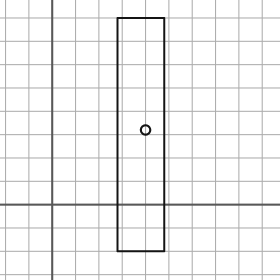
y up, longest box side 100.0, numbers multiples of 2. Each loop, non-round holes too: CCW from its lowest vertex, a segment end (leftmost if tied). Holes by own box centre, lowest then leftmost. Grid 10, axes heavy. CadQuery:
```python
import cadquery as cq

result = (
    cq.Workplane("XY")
    .moveTo(28.0, -20.0)
    .lineTo(48.0, -20.0)
    .lineTo(48.0, 80.0)
    .lineTo(28.0, 80.0)
    .close()
    .moveTo(40.0, 32.0)
    .circle(2.0)
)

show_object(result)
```